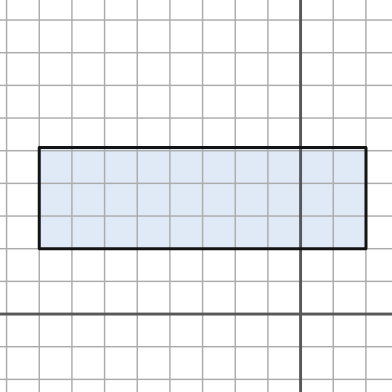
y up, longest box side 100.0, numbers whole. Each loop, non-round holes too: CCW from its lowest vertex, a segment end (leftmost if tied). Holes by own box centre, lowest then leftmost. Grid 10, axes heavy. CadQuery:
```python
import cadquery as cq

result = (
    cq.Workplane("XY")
    .moveTo(-80.0, 20.0)
    .lineTo(20.0, 20.0)
    .lineTo(20.0, 51.0)
    .lineTo(-80.0, 51.0)
    .close()
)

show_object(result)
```